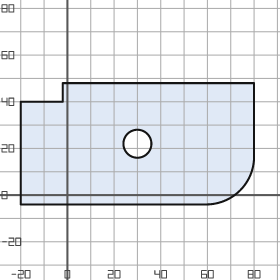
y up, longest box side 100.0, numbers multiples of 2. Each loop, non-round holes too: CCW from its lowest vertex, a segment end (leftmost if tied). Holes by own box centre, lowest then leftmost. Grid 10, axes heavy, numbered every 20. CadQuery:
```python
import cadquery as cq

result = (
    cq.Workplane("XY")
    .moveTo(-20.0, -4.0)
    .lineTo(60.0, -4.0)
    .threePointArc((74.0, 2.0), (80.0, 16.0))
    .lineTo(80.0, 48.0)
    .lineTo(-2.0, 48.0)
    .lineTo(-2.0, 40.0)
    .lineTo(-20.0, 40.0)
    .close()
    .moveTo(30.0, 22.0)
    .circle(6.0)
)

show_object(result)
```